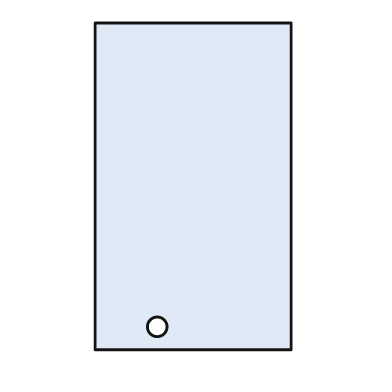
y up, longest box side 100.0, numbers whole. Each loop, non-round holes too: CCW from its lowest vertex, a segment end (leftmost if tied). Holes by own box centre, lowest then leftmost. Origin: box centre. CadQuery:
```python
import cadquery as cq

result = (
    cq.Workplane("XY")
    .moveTo(-30.0, -50.0)
    .lineTo(30.0, -50.0)
    .lineTo(30.0, 50.0)
    .lineTo(-30.0, 50.0)
    .close()
    .moveTo(-11.0, -43.0)
    .circle(3.0)
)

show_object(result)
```